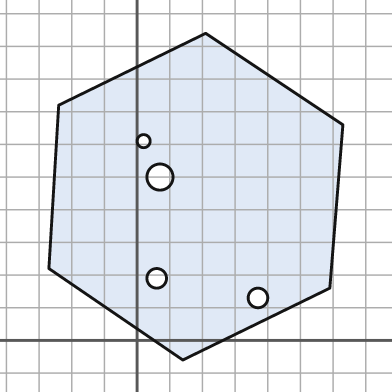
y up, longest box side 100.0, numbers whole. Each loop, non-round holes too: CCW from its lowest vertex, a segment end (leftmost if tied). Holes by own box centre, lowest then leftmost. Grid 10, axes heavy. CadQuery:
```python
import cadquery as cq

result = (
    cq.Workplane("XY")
    .moveTo(14.0, -6.0)
    .lineTo(59.0, 16.0)
    .lineTo(63.0, 66.0)
    .lineTo(21.0, 94.0)
    .lineTo(-24.0, 72.0)
    .lineTo(-27.0, 22.0)
    .close()
    .moveTo(37.0, 13.0)
    .circle(3.0)
    .moveTo(6.0, 19.0)
    .circle(3.0)
    .moveTo(7.0, 50.0)
    .circle(4.0)
    .moveTo(2.0, 61.0)
    .circle(2.0)
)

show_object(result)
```